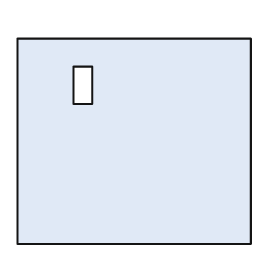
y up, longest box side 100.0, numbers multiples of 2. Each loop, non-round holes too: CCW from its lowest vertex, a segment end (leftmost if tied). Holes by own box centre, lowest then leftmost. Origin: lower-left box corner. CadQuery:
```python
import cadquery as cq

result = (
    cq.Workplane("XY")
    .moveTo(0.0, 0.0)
    .lineTo(100.0, 0.0)
    .lineTo(100.0, 88.0)
    .lineTo(0.0, 88.0)
    .close()
    .moveTo(24.0, 60.0)
    .lineTo(32.0, 60.0)
    .lineTo(32.0, 76.0)
    .lineTo(24.0, 76.0)
    .close()
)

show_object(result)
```